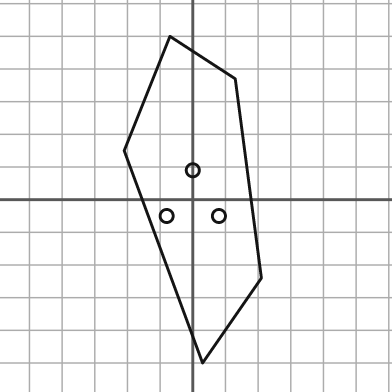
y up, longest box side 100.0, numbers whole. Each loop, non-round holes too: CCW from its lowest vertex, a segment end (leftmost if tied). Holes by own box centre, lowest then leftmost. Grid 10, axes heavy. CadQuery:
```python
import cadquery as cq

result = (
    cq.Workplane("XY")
    .moveTo(3.0, -50.0)
    .lineTo(21.0, -24.0)
    .lineTo(13.0, 37.0)
    .lineTo(-7.0, 50.0)
    .lineTo(-21.0, 15.0)
    .close()
    .moveTo(-8.0, -5.0)
    .circle(2.0)
    .moveTo(8.0, -5.0)
    .circle(2.0)
    .moveTo(0.0, 9.0)
    .circle(2.0)
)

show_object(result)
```